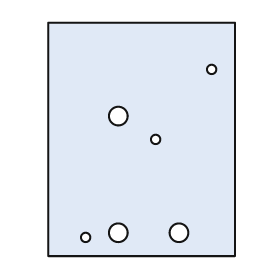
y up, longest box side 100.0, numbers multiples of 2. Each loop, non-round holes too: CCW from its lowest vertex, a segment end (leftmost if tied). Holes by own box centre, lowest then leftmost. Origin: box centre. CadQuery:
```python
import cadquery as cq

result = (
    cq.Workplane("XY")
    .moveTo(-40.0, -50.0)
    .lineTo(40.0, -50.0)
    .lineTo(40.0, 50.0)
    .lineTo(-40.0, 50.0)
    .close()
    .moveTo(-24.0, -42.0)
    .circle(2.0)
    .moveTo(-10.0, -40.0)
    .circle(4.0)
    .moveTo(16.0, -40.0)
    .circle(4.0)
    .moveTo(6.0, 0.0)
    .circle(2.0)
    .moveTo(-10.0, 10.0)
    .circle(4.0)
    .moveTo(30.0, 30.0)
    .circle(2.0)
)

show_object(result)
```